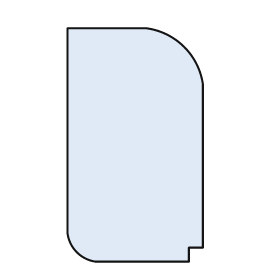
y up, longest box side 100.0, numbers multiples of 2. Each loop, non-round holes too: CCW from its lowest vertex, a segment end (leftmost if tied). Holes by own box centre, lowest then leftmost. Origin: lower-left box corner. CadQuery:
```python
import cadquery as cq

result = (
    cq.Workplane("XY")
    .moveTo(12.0, 0.0)
    .lineTo(52.0, 0.0)
    .lineTo(52.0, 6.0)
    .lineTo(58.0, 6.0)
    .lineTo(58.0, 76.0)
    .threePointArc((50.0, 92.0), (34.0, 100.0))
    .lineTo(0.0, 100.0)
    .lineTo(0.0, 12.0)
    .threePointArc((4.0, 4.0), (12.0, 0.0))
    .close()
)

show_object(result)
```